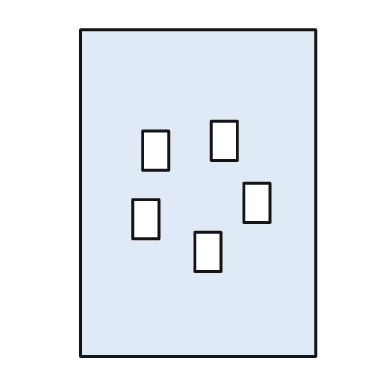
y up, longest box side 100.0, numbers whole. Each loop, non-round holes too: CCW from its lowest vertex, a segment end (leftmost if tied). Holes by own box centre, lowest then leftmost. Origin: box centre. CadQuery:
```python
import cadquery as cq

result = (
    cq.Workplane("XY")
    .moveTo(-36.0, -50.0)
    .lineTo(36.0, -50.0)
    .lineTo(36.0, 50.0)
    .lineTo(-36.0, 50.0)
    .close()
    .moveTo(-1.0, -24.0)
    .lineTo(7.0, -24.0)
    .lineTo(7.0, -12.0)
    .lineTo(-1.0, -12.0)
    .close()
    .moveTo(-20.0, -14.0)
    .lineTo(-12.0, -14.0)
    .lineTo(-12.0, -2.0)
    .lineTo(-20.0, -2.0)
    .close()
    .moveTo(14.0, -9.0)
    .lineTo(22.0, -9.0)
    .lineTo(22.0, 3.0)
    .lineTo(14.0, 3.0)
    .close()
    .moveTo(-17.0, 7.0)
    .lineTo(-9.0, 7.0)
    .lineTo(-9.0, 19.0)
    .lineTo(-17.0, 19.0)
    .close()
    .moveTo(4.0, 10.0)
    .lineTo(12.0, 10.0)
    .lineTo(12.0, 22.0)
    .lineTo(4.0, 22.0)
    .close()
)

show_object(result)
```